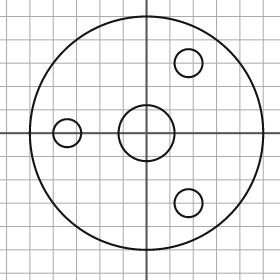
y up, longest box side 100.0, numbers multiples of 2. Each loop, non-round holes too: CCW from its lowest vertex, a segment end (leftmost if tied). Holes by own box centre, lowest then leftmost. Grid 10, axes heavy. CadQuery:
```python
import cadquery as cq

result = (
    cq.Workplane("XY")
    .moveTo(0.0, 0.0)
    .circle(50.0)
    .moveTo(18.0, -30.0)
    .circle(6.0)
    .moveTo(-34.0, 0.0)
    .circle(6.0)
    .moveTo(0.0, 0.0)
    .circle(12.0)
    .moveTo(18.0, 30.0)
    .circle(6.0)
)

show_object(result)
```